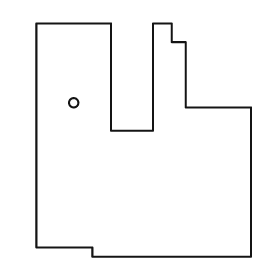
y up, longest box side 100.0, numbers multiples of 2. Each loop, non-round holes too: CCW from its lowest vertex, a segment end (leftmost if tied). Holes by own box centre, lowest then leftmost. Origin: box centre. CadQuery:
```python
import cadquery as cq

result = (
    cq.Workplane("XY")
    .moveTo(-22.0, -50.0)
    .lineTo(46.0, -50.0)
    .lineTo(46.0, 14.0)
    .lineTo(18.0, 14.0)
    .lineTo(18.0, 42.0)
    .lineTo(12.0, 42.0)
    .lineTo(12.0, 50.0)
    .lineTo(4.0, 50.0)
    .lineTo(4.0, 4.0)
    .lineTo(-14.0, 4.0)
    .lineTo(-14.0, 50.0)
    .lineTo(-46.0, 50.0)
    .lineTo(-46.0, -46.0)
    .lineTo(-22.0, -46.0)
    .close()
    .moveTo(-30.0, 16.0)
    .circle(2.0)
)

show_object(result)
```